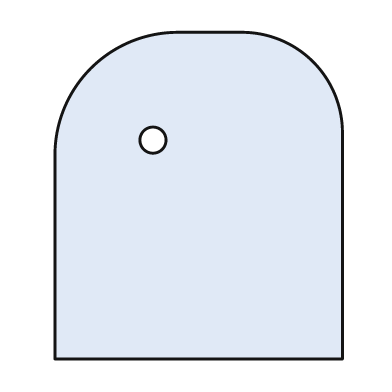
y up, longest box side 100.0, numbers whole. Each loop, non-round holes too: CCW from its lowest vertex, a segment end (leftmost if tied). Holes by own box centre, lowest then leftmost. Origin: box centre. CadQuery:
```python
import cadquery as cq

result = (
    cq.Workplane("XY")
    .moveTo(-44.0, -50.0)
    .lineTo(44.0, -50.0)
    .lineTo(44.0, 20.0)
    .threePointArc((35.0, 41.0), (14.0, 50.0))
    .lineTo(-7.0, 50.0)
    .threePointArc((-33.0, 39.0), (-44.0, 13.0))
    .close()
    .moveTo(-14.0, 17.0)
    .circle(4.0)
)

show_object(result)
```